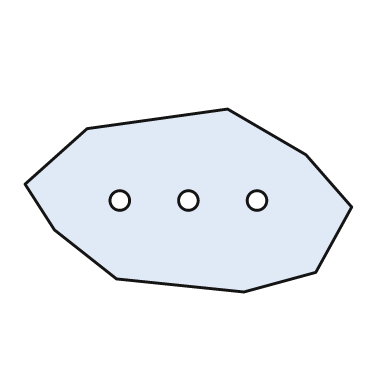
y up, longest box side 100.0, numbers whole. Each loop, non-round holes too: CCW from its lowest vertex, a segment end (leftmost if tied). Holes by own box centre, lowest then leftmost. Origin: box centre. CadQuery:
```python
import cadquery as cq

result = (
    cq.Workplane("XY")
    .moveTo(17.0, -28.0)
    .lineTo(39.0, -22.0)
    .lineTo(50.0, -2.0)
    .lineTo(36.0, 14.0)
    .lineTo(12.0, 28.0)
    .lineTo(-31.0, 22.0)
    .lineTo(-50.0, 5.0)
    .lineTo(-41.0, -9.0)
    .lineTo(-22.0, -24.0)
    .close()
    .moveTo(-21.0, 0.0)
    .circle(3.0)
    .moveTo(0.0, 0.0)
    .circle(3.0)
    .moveTo(21.0, 0.0)
    .circle(3.0)
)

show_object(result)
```